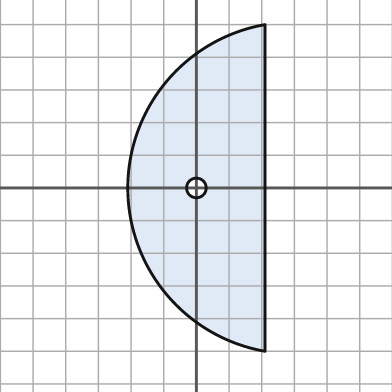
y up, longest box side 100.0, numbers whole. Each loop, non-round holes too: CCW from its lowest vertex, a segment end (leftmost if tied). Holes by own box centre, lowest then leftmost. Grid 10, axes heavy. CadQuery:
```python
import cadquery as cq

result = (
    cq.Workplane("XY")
    .moveTo(21.0, -50.0)
    .lineTo(21.0, 50.0)
    .threePointArc((-21.0, 0.0), (21.0, -50.0))
    .close()
    .moveTo(0.0, 0.0)
    .circle(3.0)
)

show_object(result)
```